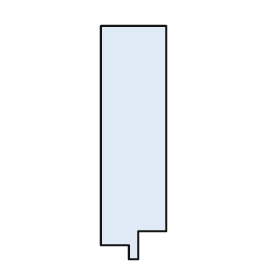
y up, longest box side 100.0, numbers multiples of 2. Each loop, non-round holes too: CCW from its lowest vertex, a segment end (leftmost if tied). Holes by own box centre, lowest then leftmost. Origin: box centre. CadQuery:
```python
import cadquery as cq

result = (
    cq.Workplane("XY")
    .moveTo(-2.0, -50.0)
    .lineTo(2.0, -50.0)
    .lineTo(2.0, -38.0)
    .lineTo(14.0, -38.0)
    .lineTo(14.0, 50.0)
    .lineTo(-14.0, 50.0)
    .lineTo(-14.0, -44.0)
    .lineTo(-2.0, -44.0)
    .close()
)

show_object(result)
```